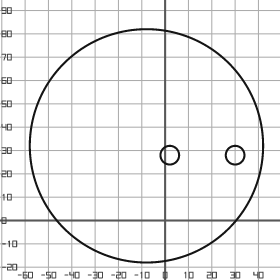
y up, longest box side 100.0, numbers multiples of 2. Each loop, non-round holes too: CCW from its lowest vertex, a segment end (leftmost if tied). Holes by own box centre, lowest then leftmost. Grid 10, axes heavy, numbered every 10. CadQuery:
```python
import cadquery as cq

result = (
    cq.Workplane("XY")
    .moveTo(-8.0, 32.0)
    .circle(50.0)
    .moveTo(2.0, 28.0)
    .circle(4.0)
    .moveTo(30.0, 28.0)
    .circle(4.0)
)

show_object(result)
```